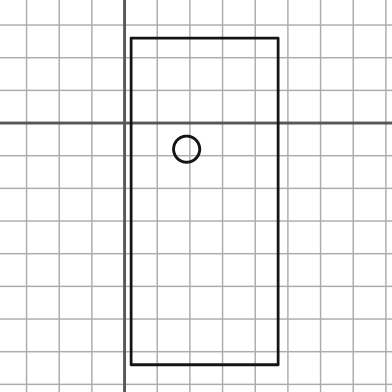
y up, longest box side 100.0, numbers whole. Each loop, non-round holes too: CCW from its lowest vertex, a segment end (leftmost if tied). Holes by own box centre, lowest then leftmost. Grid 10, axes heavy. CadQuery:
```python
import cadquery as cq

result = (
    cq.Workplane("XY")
    .moveTo(2.0, -74.0)
    .lineTo(47.0, -74.0)
    .lineTo(47.0, 26.0)
    .lineTo(2.0, 26.0)
    .close()
    .moveTo(19.0, -8.0)
    .circle(4.0)
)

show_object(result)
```